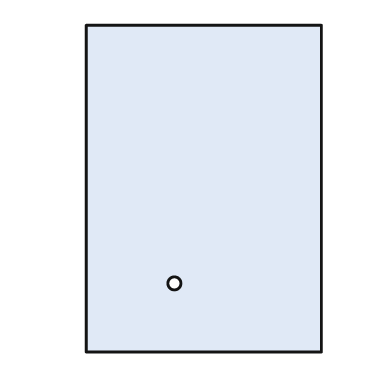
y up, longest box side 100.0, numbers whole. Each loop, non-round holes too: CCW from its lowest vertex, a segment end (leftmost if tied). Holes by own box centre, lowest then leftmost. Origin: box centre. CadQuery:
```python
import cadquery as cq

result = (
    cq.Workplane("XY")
    .moveTo(-36.0, -50.0)
    .lineTo(36.0, -50.0)
    .lineTo(36.0, 50.0)
    .lineTo(-36.0, 50.0)
    .close()
    .moveTo(-9.0, -29.0)
    .circle(2.0)
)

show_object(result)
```